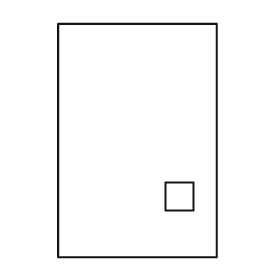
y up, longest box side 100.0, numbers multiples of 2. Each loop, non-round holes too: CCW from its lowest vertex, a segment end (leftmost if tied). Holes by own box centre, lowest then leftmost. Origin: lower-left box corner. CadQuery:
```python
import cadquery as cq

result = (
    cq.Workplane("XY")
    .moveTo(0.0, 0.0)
    .lineTo(68.0, 0.0)
    .lineTo(68.0, 100.0)
    .lineTo(0.0, 100.0)
    .close()
    .moveTo(46.0, 20.0)
    .lineTo(58.0, 20.0)
    .lineTo(58.0, 32.0)
    .lineTo(46.0, 32.0)
    .close()
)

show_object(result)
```